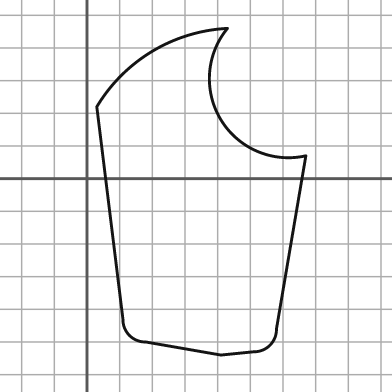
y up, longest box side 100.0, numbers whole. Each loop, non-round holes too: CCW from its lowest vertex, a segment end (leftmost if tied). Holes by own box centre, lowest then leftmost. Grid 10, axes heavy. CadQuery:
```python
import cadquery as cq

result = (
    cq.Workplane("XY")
    .moveTo(41.0, -54.0)
    .lineTo(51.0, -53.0)
    .threePointArc((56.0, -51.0), (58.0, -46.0))
    .lineTo(67.0, 7.0)
    .threePointArc((41.0, 18.0), (43.0, 46.0))
    .threePointArc((20.0, 39.0), (3.0, 22.0))
    .lineTo(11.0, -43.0)
    .threePointArc((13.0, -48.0), (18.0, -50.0))
    .close()
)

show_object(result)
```